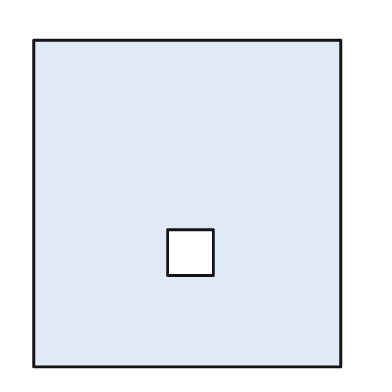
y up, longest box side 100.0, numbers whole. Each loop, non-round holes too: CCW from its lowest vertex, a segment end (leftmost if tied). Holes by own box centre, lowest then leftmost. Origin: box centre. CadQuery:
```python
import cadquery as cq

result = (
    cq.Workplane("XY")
    .moveTo(-47.0, -50.0)
    .lineTo(47.0, -50.0)
    .lineTo(47.0, 50.0)
    .lineTo(-47.0, 50.0)
    .close()
    .moveTo(-6.0, -22.0)
    .lineTo(8.0, -22.0)
    .lineTo(8.0, -8.0)
    .lineTo(-6.0, -8.0)
    .close()
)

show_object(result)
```